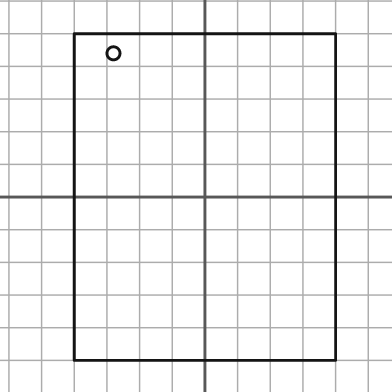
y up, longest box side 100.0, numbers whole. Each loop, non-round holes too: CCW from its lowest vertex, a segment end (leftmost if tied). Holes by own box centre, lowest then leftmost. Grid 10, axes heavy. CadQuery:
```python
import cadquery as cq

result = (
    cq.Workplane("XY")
    .moveTo(-40.0, -50.0)
    .lineTo(40.0, -50.0)
    .lineTo(40.0, 50.0)
    .lineTo(-40.0, 50.0)
    .close()
    .moveTo(-28.0, 44.0)
    .circle(2.0)
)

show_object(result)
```